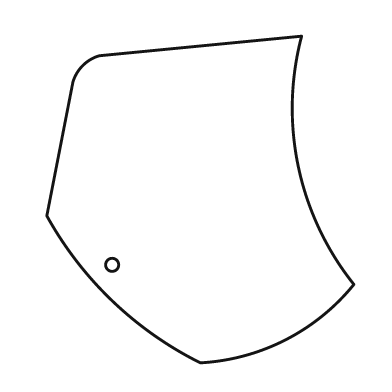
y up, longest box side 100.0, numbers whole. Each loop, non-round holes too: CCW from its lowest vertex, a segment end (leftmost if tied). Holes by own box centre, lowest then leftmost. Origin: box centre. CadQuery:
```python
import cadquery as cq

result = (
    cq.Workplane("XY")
    .moveTo(0.0, -50.0)
    .threePointArc((26.0, -43.0), (47.0, -26.0))
    .threePointArc((30.0, 10.0), (31.0, 50.0))
    .lineTo(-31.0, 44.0)
    .threePointArc((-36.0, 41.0), (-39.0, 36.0))
    .lineTo(-47.0, -5.0)
    .threePointArc((-27.0, -31.0), (0.0, -50.0))
    .close()
    .moveTo(-27.0, -20.0)
    .circle(2.0)
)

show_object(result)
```